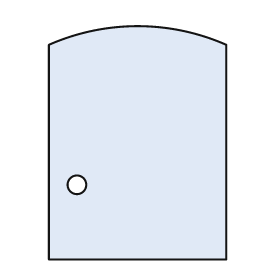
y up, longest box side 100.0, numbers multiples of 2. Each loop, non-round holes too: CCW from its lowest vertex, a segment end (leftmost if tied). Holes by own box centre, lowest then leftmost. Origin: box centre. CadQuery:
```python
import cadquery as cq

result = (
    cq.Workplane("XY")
    .moveTo(-38.0, -50.0)
    .lineTo(38.0, -50.0)
    .lineTo(38.0, 42.0)
    .threePointArc((0.0, 50.0), (-38.0, 42.0))
    .close()
    .moveTo(-26.0, -18.0)
    .circle(4.0)
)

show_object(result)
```